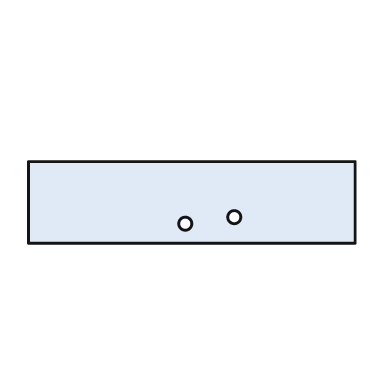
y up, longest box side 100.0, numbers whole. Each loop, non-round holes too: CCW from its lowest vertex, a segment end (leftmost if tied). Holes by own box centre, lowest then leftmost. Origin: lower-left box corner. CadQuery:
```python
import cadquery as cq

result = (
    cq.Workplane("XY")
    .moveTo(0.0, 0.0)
    .lineTo(100.0, 0.0)
    .lineTo(100.0, 25.0)
    .lineTo(0.0, 25.0)
    .close()
    .moveTo(48.0, 6.0)
    .circle(2.0)
    .moveTo(63.0, 8.0)
    .circle(2.0)
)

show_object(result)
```